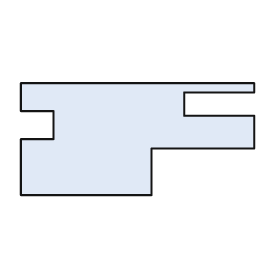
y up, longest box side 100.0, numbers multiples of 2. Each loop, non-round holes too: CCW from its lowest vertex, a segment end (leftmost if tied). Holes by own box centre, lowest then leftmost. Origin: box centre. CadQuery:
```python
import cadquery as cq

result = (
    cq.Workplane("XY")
    .moveTo(-50.0, -24.0)
    .lineTo(6.0, -24.0)
    .lineTo(6.0, -4.0)
    .lineTo(50.0, -4.0)
    .lineTo(50.0, 10.0)
    .lineTo(20.0, 10.0)
    .lineTo(20.0, 20.0)
    .lineTo(50.0, 20.0)
    .lineTo(50.0, 24.0)
    .lineTo(-50.0, 24.0)
    .lineTo(-50.0, 12.0)
    .lineTo(-36.0, 12.0)
    .lineTo(-36.0, 0.0)
    .lineTo(-50.0, 0.0)
    .close()
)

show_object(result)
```